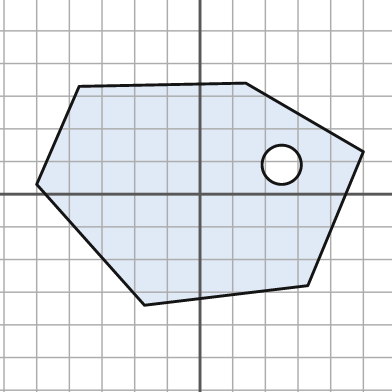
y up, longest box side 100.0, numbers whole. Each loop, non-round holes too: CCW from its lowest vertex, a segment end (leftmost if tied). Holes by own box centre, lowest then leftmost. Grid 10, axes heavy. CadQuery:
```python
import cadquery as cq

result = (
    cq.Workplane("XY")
    .moveTo(-17.0, -34.0)
    .lineTo(33.0, -28.0)
    .lineTo(50.0, 13.0)
    .lineTo(14.0, 34.0)
    .lineTo(-37.0, 33.0)
    .lineTo(-50.0, 3.0)
    .close()
    .moveTo(25.0, 9.0)
    .circle(6.0)
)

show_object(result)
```